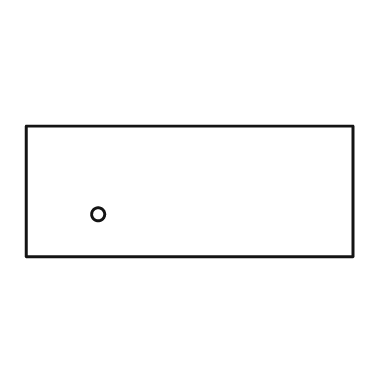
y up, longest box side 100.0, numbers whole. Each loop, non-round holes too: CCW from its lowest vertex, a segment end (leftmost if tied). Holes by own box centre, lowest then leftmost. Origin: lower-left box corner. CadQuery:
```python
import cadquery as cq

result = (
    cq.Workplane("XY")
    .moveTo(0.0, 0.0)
    .lineTo(100.0, 0.0)
    .lineTo(100.0, 40.0)
    .lineTo(0.0, 40.0)
    .close()
    .moveTo(22.0, 13.0)
    .circle(2.0)
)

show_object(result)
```